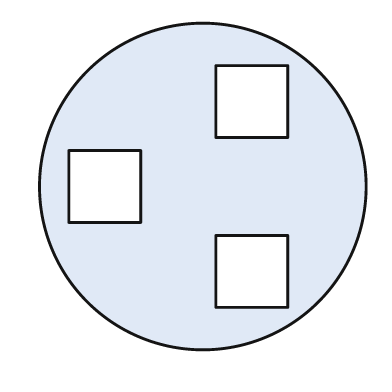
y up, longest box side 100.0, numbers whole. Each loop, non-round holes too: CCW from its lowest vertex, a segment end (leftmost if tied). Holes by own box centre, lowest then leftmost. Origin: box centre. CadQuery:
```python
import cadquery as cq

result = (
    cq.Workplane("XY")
    .moveTo(0.0, 0.0)
    .circle(50.0)
    .moveTo(4.0, -37.0)
    .lineTo(26.0, -37.0)
    .lineTo(26.0, -15.0)
    .lineTo(4.0, -15.0)
    .close()
    .moveTo(-41.0, -11.0)
    .lineTo(-19.0, -11.0)
    .lineTo(-19.0, 11.0)
    .lineTo(-41.0, 11.0)
    .close()
    .moveTo(4.0, 15.0)
    .lineTo(26.0, 15.0)
    .lineTo(26.0, 37.0)
    .lineTo(4.0, 37.0)
    .close()
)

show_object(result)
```